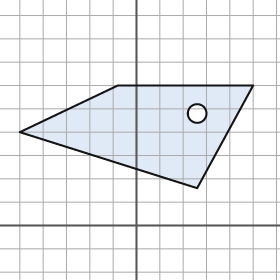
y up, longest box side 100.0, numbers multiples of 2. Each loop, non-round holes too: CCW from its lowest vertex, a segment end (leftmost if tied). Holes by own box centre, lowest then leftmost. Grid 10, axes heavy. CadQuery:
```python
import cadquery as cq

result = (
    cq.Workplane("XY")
    .moveTo(26.0, 16.0)
    .lineTo(50.0, 60.0)
    .lineTo(-8.0, 60.0)
    .lineTo(-50.0, 40.0)
    .close()
    .moveTo(26.0, 48.0)
    .circle(4.0)
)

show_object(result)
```